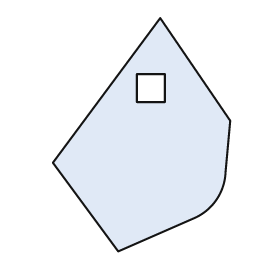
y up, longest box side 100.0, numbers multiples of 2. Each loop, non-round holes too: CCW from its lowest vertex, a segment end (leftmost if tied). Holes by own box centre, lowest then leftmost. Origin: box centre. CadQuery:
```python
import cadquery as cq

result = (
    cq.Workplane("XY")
    .moveTo(-10.0, -50.0)
    .lineTo(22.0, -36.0)
    .threePointArc((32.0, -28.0), (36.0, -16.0))
    .lineTo(38.0, 6.0)
    .lineTo(8.0, 50.0)
    .lineTo(-38.0, -12.0)
    .close()
    .moveTo(-2.0, 14.0)
    .lineTo(10.0, 14.0)
    .lineTo(10.0, 26.0)
    .lineTo(-2.0, 26.0)
    .close()
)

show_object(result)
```